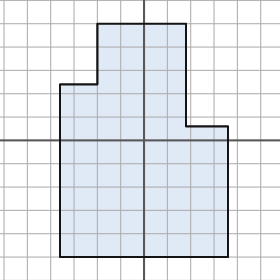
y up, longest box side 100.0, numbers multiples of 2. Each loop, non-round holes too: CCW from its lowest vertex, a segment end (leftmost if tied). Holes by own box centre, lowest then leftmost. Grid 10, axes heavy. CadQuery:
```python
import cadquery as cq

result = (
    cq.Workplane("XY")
    .moveTo(-36.0, -50.0)
    .lineTo(36.0, -50.0)
    .lineTo(36.0, 6.0)
    .lineTo(18.0, 6.0)
    .lineTo(18.0, 50.0)
    .lineTo(-20.0, 50.0)
    .lineTo(-20.0, 24.0)
    .lineTo(-36.0, 24.0)
    .close()
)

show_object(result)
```